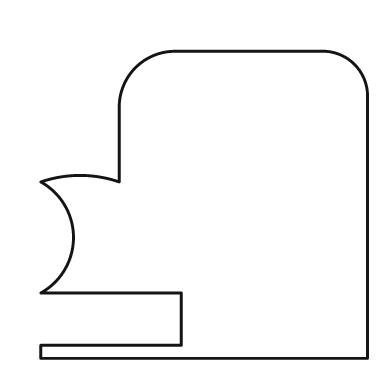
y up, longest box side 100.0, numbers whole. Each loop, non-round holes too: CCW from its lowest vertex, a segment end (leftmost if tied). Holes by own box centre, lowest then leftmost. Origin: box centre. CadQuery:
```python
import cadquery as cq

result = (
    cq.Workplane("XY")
    .moveTo(-50.0, -47.0)
    .lineTo(50.0, -47.0)
    .lineTo(50.0, 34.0)
    .threePointArc((46.0, 43.0), (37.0, 47.0))
    .lineTo(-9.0, 47.0)
    .threePointArc((-21.0, 42.0), (-26.0, 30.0))
    .lineTo(-26.0, 7.0)
    .threePointArc((-38.0, 9.0), (-50.0, 7.0))
    .threePointArc((-40.0, -10.0), (-50.0, -27.0))
    .lineTo(-7.0, -27.0)
    .lineTo(-7.0, -43.0)
    .lineTo(-50.0, -43.0)
    .close()
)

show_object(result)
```